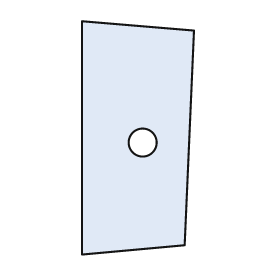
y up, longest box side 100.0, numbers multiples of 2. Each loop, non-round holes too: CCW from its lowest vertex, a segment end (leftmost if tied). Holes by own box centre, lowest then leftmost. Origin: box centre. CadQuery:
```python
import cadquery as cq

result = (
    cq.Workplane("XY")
    .moveTo(-24.0, -50.0)
    .lineTo(20.0, -46.0)
    .lineTo(24.0, 46.0)
    .lineTo(-24.0, 50.0)
    .close()
    .moveTo(2.0, -2.0)
    .circle(6.0)
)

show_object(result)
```